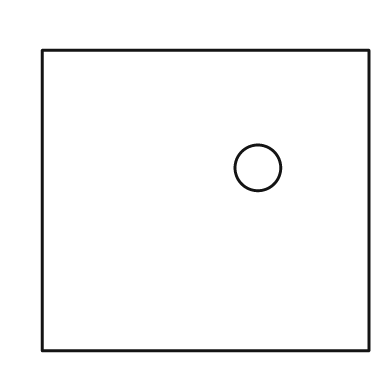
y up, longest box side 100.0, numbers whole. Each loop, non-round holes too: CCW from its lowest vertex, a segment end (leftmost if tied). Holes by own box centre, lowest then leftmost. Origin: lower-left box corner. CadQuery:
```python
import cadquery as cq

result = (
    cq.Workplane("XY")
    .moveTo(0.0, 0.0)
    .lineTo(100.0, 0.0)
    .lineTo(100.0, 92.0)
    .lineTo(0.0, 92.0)
    .close()
    .moveTo(66.0, 56.0)
    .circle(7.0)
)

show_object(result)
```